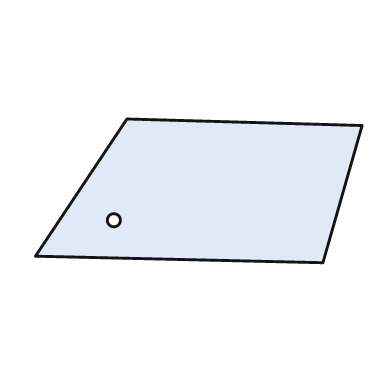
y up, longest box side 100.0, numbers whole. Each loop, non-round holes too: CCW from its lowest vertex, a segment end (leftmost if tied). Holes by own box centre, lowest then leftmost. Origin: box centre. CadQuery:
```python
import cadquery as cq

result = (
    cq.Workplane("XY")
    .moveTo(38.0, -22.0)
    .lineTo(50.0, 20.0)
    .lineTo(-22.0, 22.0)
    .lineTo(-50.0, -20.0)
    .close()
    .moveTo(-26.0, -9.0)
    .circle(2.0)
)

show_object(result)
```